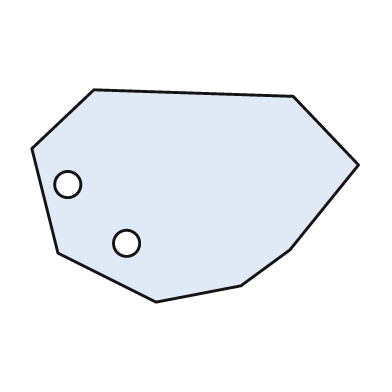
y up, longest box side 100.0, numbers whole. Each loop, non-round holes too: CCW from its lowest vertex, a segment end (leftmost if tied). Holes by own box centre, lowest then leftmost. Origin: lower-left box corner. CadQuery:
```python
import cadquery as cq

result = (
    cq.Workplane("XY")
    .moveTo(38.0, 0.0)
    .lineTo(64.0, 5.0)
    .lineTo(79.0, 16.0)
    .lineTo(100.0, 42.0)
    .lineTo(80.0, 63.0)
    .lineTo(19.0, 65.0)
    .lineTo(0.0, 47.0)
    .lineTo(8.0, 15.0)
    .close()
    .moveTo(29.0, 18.0)
    .circle(4.0)
    .moveTo(11.0, 36.0)
    .circle(4.0)
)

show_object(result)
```